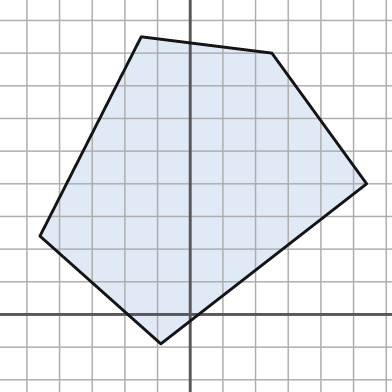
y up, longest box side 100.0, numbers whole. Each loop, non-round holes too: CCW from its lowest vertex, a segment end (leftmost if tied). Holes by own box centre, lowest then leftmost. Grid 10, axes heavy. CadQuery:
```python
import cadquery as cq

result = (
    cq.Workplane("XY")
    .moveTo(-9.0, -9.0)
    .lineTo(54.0, 40.0)
    .lineTo(25.0, 80.0)
    .lineTo(-15.0, 85.0)
    .lineTo(-46.0, 24.0)
    .close()
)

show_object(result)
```